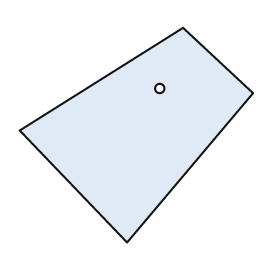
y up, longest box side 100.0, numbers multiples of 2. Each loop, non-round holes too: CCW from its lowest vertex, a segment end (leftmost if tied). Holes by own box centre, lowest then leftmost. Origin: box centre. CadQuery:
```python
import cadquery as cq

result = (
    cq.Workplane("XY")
    .moveTo(-4.0, -46.0)
    .lineTo(50.0, 18.0)
    .lineTo(20.0, 46.0)
    .lineTo(-50.0, 2.0)
    .close()
    .moveTo(10.0, 20.0)
    .circle(2.0)
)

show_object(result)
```